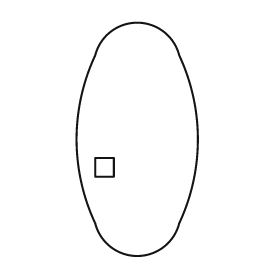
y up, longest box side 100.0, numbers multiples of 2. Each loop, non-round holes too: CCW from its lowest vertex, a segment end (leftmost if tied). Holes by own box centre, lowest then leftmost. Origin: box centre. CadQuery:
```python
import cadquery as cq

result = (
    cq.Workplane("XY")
    .moveTo(-18.0, -36.0)
    .threePointArc((0.0, -50.0), (18.0, -36.0))
    .threePointArc((26.0, 0.0), (18.0, 36.0))
    .threePointArc((0.0, 50.0), (-18.0, 36.0))
    .threePointArc((-26.0, 0.0), (-18.0, -36.0))
    .close()
    .moveTo(-18.0, -16.0)
    .lineTo(-10.0, -16.0)
    .lineTo(-10.0, -8.0)
    .lineTo(-18.0, -8.0)
    .close()
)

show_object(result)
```